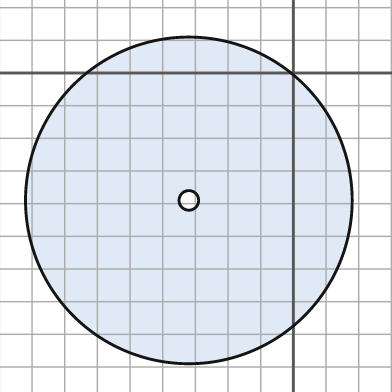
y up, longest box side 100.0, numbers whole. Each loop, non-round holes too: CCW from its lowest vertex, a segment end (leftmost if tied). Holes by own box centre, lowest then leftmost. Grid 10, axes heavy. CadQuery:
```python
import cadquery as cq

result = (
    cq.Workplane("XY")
    .moveTo(-32.0, -39.0)
    .circle(50.0)
    .moveTo(-32.0, -39.0)
    .circle(3.0)
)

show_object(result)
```